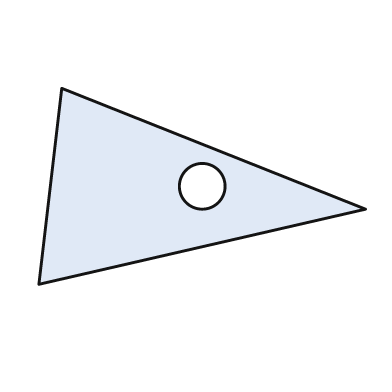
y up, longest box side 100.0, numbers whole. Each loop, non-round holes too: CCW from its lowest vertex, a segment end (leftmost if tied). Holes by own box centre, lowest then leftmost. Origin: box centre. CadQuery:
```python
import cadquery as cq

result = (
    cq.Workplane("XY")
    .moveTo(-50.0, -30.0)
    .lineTo(50.0, -7.0)
    .lineTo(-43.0, 30.0)
    .close()
    .moveTo(0.0, 0.0)
    .circle(7.0)
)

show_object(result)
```